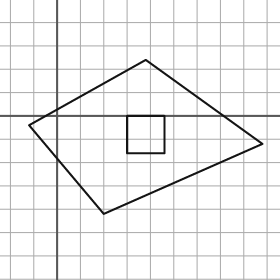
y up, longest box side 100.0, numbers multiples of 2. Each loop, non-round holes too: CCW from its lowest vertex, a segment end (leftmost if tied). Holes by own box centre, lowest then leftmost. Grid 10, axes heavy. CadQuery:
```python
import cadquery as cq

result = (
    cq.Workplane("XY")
    .moveTo(20.0, -42.0)
    .lineTo(88.0, -12.0)
    .lineTo(38.0, 24.0)
    .lineTo(-12.0, -4.0)
    .close()
    .moveTo(30.0, -16.0)
    .lineTo(46.0, -16.0)
    .lineTo(46.0, 0.0)
    .lineTo(30.0, 0.0)
    .close()
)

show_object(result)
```